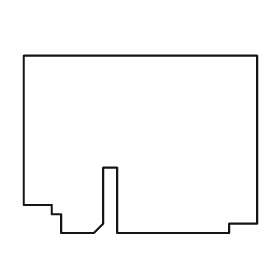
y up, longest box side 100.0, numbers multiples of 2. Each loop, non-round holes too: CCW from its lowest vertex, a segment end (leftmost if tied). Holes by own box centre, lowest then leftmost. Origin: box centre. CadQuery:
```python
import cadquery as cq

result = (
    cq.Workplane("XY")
    .moveTo(-34.0, -38.0)
    .lineTo(-20.0, -38.0)
    .lineTo(-16.0, -34.0)
    .lineTo(-16.0, -10.0)
    .lineTo(-10.0, -10.0)
    .lineTo(-10.0, -38.0)
    .lineTo(38.0, -38.0)
    .lineTo(38.0, -34.0)
    .lineTo(50.0, -34.0)
    .lineTo(50.0, 38.0)
    .lineTo(-50.0, 38.0)
    .lineTo(-50.0, -26.0)
    .lineTo(-38.0, -26.0)
    .lineTo(-38.0, -30.0)
    .lineTo(-34.0, -30.0)
    .close()
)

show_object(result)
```